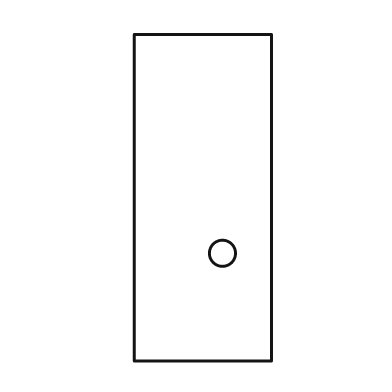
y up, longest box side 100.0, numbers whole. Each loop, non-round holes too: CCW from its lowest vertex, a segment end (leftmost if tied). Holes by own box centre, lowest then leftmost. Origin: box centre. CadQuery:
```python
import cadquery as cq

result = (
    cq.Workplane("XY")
    .moveTo(-21.0, -50.0)
    .lineTo(21.0, -50.0)
    .lineTo(21.0, 50.0)
    .lineTo(-21.0, 50.0)
    .close()
    .moveTo(6.0, -17.0)
    .circle(4.0)
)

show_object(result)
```